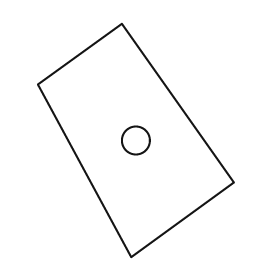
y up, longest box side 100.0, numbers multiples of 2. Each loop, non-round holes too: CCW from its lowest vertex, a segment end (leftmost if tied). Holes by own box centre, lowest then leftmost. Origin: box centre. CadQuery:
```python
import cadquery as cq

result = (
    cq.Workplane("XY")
    .moveTo(-2.0, -50.0)
    .lineTo(42.0, -18.0)
    .lineTo(-6.0, 50.0)
    .lineTo(-42.0, 24.0)
    .close()
    .moveTo(0.0, 0.0)
    .circle(6.0)
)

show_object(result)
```